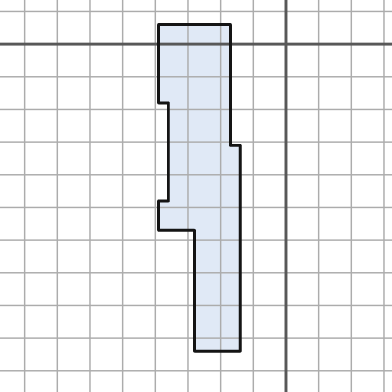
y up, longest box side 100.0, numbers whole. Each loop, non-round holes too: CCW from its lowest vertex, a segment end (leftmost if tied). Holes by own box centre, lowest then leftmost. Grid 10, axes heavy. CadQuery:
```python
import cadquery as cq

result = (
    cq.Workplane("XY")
    .moveTo(-28.0, -94.0)
    .lineTo(-14.0, -94.0)
    .lineTo(-14.0, -31.0)
    .lineTo(-17.0, -31.0)
    .lineTo(-17.0, 6.0)
    .lineTo(-39.0, 6.0)
    .lineTo(-39.0, -18.0)
    .lineTo(-36.0, -18.0)
    .lineTo(-36.0, -48.0)
    .lineTo(-39.0, -48.0)
    .lineTo(-39.0, -57.0)
    .lineTo(-28.0, -57.0)
    .close()
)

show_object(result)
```